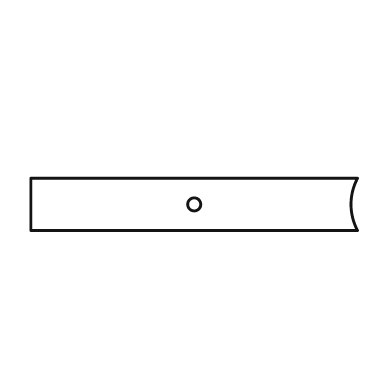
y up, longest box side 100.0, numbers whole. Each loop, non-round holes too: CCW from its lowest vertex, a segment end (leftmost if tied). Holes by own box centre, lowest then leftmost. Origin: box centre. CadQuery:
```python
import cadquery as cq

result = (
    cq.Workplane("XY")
    .moveTo(-50.0, -8.0)
    .lineTo(50.0, -8.0)
    .threePointArc((48.0, 0.0), (50.0, 8.0))
    .lineTo(-50.0, 8.0)
    .close()
    .moveTo(0.0, 0.0)
    .circle(2.0)
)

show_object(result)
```